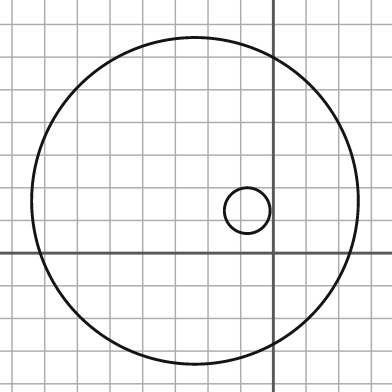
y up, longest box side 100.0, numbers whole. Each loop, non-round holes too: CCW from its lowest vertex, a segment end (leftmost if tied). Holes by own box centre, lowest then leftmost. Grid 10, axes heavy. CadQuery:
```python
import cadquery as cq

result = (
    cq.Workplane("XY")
    .moveTo(-24.0, 16.0)
    .circle(50.0)
    .moveTo(-8.0, 13.0)
    .circle(7.0)
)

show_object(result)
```